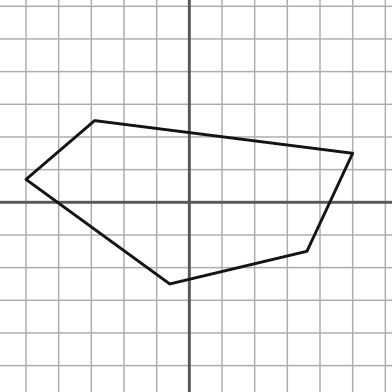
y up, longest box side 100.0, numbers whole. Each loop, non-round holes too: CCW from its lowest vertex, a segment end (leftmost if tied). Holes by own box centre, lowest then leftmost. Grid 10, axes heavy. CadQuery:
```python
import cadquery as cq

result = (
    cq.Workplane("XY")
    .moveTo(-6.0, -25.0)
    .lineTo(36.0, -15.0)
    .lineTo(50.0, 15.0)
    .lineTo(-29.0, 25.0)
    .lineTo(-50.0, 7.0)
    .close()
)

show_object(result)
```